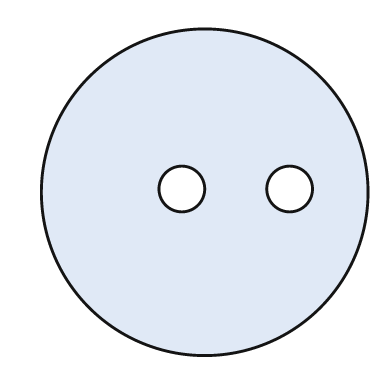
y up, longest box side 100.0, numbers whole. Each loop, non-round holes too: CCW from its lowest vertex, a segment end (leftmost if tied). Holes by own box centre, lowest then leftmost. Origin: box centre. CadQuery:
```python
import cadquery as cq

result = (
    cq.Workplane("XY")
    .moveTo(0.0, 0.0)
    .circle(50.0)
    .moveTo(-7.0, 1.0)
    .circle(7.0)
    .moveTo(26.0, 1.0)
    .circle(7.0)
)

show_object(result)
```